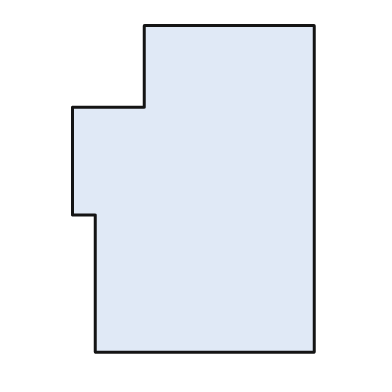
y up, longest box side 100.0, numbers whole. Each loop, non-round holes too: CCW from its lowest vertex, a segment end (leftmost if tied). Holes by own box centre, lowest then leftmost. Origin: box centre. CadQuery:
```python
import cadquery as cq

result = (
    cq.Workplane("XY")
    .moveTo(-30.0, -50.0)
    .lineTo(37.0, -50.0)
    .lineTo(37.0, 50.0)
    .lineTo(-15.0, 50.0)
    .lineTo(-15.0, 25.0)
    .lineTo(-37.0, 25.0)
    .lineTo(-37.0, -8.0)
    .lineTo(-30.0, -8.0)
    .close()
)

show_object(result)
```